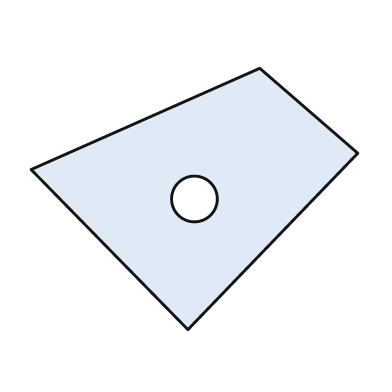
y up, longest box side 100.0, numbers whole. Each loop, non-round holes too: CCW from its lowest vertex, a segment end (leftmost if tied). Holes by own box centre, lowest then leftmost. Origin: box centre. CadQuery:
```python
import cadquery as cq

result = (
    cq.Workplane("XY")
    .moveTo(-2.0, -40.0)
    .lineTo(50.0, 14.0)
    .lineTo(20.0, 40.0)
    .lineTo(-50.0, 9.0)
    .close()
    .moveTo(0.0, 0.0)
    .circle(7.0)
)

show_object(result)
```